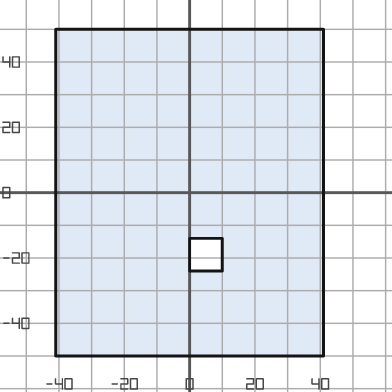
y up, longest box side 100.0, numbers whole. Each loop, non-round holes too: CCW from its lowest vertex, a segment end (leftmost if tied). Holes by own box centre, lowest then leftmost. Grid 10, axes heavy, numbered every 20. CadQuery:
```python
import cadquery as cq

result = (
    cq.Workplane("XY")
    .moveTo(-41.0, -50.0)
    .lineTo(41.0, -50.0)
    .lineTo(41.0, 50.0)
    .lineTo(-41.0, 50.0)
    .close()
    .moveTo(0.0, -24.0)
    .lineTo(10.0, -24.0)
    .lineTo(10.0, -14.0)
    .lineTo(0.0, -14.0)
    .close()
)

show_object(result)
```